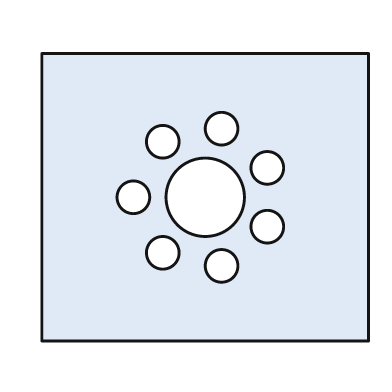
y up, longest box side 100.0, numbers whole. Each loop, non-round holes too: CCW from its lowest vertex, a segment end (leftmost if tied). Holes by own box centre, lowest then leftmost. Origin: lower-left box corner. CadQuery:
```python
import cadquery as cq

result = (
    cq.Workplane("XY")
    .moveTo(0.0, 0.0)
    .lineTo(100.0, 0.0)
    .lineTo(100.0, 88.0)
    .lineTo(0.0, 88.0)
    .close()
    .moveTo(55.0, 23.0)
    .circle(5.0)
    .moveTo(37.0, 27.0)
    .circle(5.0)
    .moveTo(69.0, 35.0)
    .circle(5.0)
    .moveTo(28.0, 44.0)
    .circle(5.0)
    .moveTo(50.0, 44.0)
    .circle(12.0)
    .moveTo(69.0, 53.0)
    .circle(5.0)
    .moveTo(37.0, 61.0)
    .circle(5.0)
    .moveTo(55.0, 65.0)
    .circle(5.0)
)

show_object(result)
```